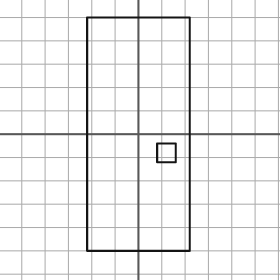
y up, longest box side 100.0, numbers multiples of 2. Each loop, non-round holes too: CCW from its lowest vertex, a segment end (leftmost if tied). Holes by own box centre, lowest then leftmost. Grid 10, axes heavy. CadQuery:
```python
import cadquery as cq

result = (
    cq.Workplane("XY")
    .moveTo(-22.0, -50.0)
    .lineTo(22.0, -50.0)
    .lineTo(22.0, 50.0)
    .lineTo(-22.0, 50.0)
    .close()
    .moveTo(8.0, -12.0)
    .lineTo(16.0, -12.0)
    .lineTo(16.0, -4.0)
    .lineTo(8.0, -4.0)
    .close()
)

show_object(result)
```